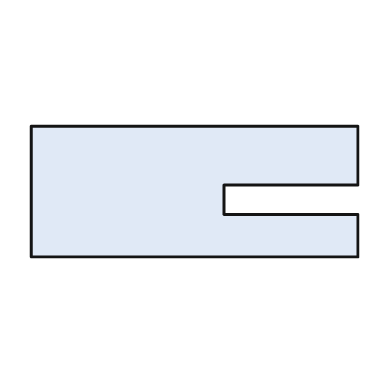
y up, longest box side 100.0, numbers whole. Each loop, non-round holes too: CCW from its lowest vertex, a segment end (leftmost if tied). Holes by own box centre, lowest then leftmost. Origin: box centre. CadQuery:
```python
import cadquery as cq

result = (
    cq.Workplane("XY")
    .moveTo(-50.0, -20.0)
    .lineTo(50.0, -20.0)
    .lineTo(50.0, -7.0)
    .lineTo(9.0, -7.0)
    .lineTo(9.0, 2.0)
    .lineTo(50.0, 2.0)
    .lineTo(50.0, 20.0)
    .lineTo(-50.0, 20.0)
    .close()
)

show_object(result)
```